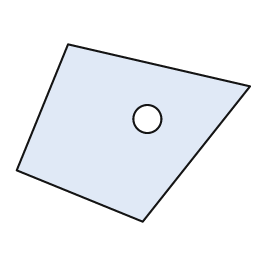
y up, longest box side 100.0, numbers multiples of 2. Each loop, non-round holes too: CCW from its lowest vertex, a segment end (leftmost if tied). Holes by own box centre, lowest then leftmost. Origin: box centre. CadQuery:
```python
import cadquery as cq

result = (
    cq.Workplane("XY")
    .moveTo(4.0, -38.0)
    .lineTo(50.0, 20.0)
    .lineTo(-28.0, 38.0)
    .lineTo(-50.0, -16.0)
    .close()
    .moveTo(6.0, 6.0)
    .circle(6.0)
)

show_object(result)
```